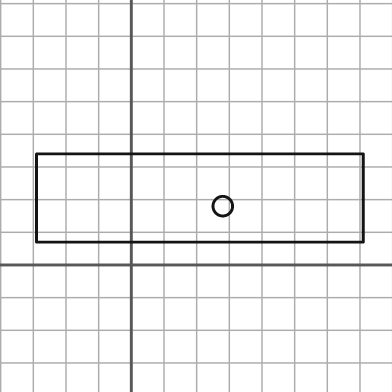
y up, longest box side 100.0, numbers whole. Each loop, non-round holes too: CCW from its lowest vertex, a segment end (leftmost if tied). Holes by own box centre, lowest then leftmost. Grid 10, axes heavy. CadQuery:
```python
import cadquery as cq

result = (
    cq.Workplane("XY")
    .moveTo(-29.0, 7.0)
    .lineTo(71.0, 7.0)
    .lineTo(71.0, 34.0)
    .lineTo(-29.0, 34.0)
    .close()
    .moveTo(28.0, 18.0)
    .circle(3.0)
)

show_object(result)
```